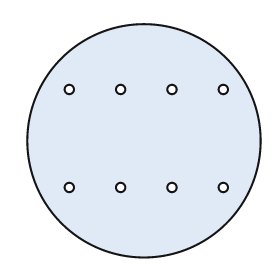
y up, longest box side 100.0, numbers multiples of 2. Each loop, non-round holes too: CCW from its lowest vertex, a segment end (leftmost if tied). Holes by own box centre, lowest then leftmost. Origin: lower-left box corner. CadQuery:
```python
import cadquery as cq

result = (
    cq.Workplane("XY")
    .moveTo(50.0, 50.0)
    .circle(50.0)
    .moveTo(18.0, 30.0)
    .circle(2.0)
    .moveTo(40.0, 30.0)
    .circle(2.0)
    .moveTo(62.0, 30.0)
    .circle(2.0)
    .moveTo(84.0, 30.0)
    .circle(2.0)
    .moveTo(18.0, 72.0)
    .circle(2.0)
    .moveTo(40.0, 72.0)
    .circle(2.0)
    .moveTo(62.0, 72.0)
    .circle(2.0)
    .moveTo(84.0, 72.0)
    .circle(2.0)
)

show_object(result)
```